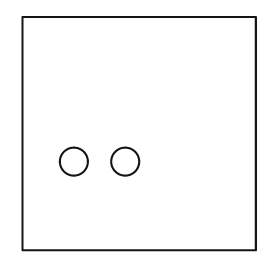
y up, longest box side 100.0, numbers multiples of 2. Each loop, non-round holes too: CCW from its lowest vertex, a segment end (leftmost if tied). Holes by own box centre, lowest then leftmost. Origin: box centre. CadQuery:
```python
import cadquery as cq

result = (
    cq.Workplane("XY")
    .moveTo(-50.0, -50.0)
    .lineTo(50.0, -50.0)
    .lineTo(50.0, 50.0)
    .lineTo(-50.0, 50.0)
    .close()
    .moveTo(-28.0, -12.0)
    .circle(6.0)
    .moveTo(-6.0, -12.0)
    .circle(6.0)
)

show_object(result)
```